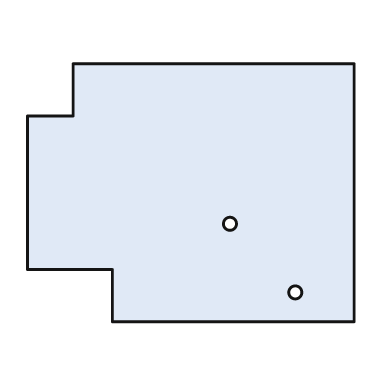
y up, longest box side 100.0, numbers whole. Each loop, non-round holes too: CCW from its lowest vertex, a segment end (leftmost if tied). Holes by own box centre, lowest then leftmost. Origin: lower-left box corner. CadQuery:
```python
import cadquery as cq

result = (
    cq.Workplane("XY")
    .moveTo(26.0, 0.0)
    .lineTo(100.0, 0.0)
    .lineTo(100.0, 79.0)
    .lineTo(14.0, 79.0)
    .lineTo(14.0, 63.0)
    .lineTo(0.0, 63.0)
    .lineTo(0.0, 16.0)
    .lineTo(26.0, 16.0)
    .close()
    .moveTo(82.0, 9.0)
    .circle(2.0)
    .moveTo(62.0, 30.0)
    .circle(2.0)
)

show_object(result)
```